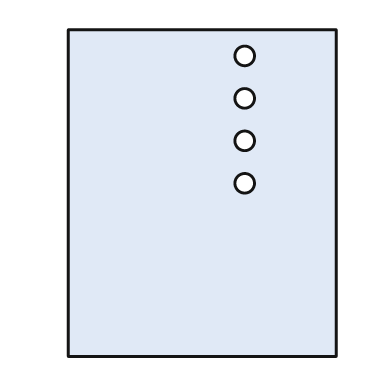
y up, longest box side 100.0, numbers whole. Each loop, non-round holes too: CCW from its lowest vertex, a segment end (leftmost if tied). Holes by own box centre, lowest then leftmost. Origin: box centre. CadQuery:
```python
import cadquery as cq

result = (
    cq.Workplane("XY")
    .moveTo(-41.0, -50.0)
    .lineTo(41.0, -50.0)
    .lineTo(41.0, 50.0)
    .lineTo(-41.0, 50.0)
    .close()
    .moveTo(13.0, 3.0)
    .circle(3.0)
    .moveTo(13.0, 16.0)
    .circle(3.0)
    .moveTo(13.0, 29.0)
    .circle(3.0)
    .moveTo(13.0, 42.0)
    .circle(3.0)
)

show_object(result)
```